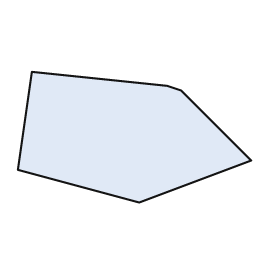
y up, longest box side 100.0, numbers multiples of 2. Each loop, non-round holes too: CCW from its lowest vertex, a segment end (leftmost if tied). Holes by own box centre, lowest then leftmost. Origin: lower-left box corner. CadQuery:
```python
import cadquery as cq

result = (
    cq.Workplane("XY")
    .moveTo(52.0, 0.0)
    .lineTo(100.0, 18.0)
    .lineTo(70.0, 48.0)
    .lineTo(64.0, 50.0)
    .lineTo(6.0, 56.0)
    .lineTo(0.0, 14.0)
    .close()
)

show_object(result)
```